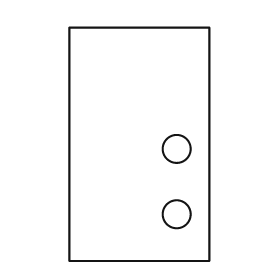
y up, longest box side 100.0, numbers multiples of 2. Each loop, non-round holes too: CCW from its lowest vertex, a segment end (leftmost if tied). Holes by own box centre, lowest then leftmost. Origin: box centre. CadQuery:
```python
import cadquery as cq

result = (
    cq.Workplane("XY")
    .moveTo(-30.0, -50.0)
    .lineTo(30.0, -50.0)
    .lineTo(30.0, 50.0)
    .lineTo(-30.0, 50.0)
    .close()
    .moveTo(16.0, -30.0)
    .circle(6.0)
    .moveTo(16.0, -2.0)
    .circle(6.0)
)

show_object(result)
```